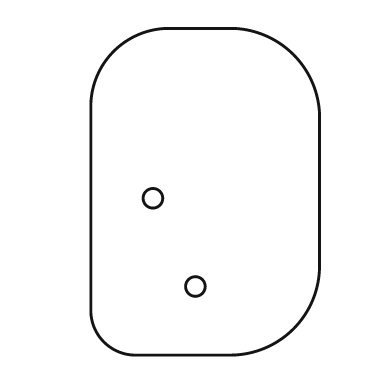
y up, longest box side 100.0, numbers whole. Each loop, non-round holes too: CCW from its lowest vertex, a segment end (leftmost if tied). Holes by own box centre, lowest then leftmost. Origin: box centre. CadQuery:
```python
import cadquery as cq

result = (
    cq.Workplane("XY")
    .moveTo(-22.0, -50.0)
    .lineTo(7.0, -50.0)
    .threePointArc((27.0, -42.0), (35.0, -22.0))
    .lineTo(35.0, 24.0)
    .threePointArc((27.0, 42.0), (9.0, 50.0))
    .lineTo(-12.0, 50.0)
    .threePointArc((-28.0, 43.0), (-35.0, 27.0))
    .lineTo(-35.0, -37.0)
    .threePointArc((-31.0, -46.0), (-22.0, -50.0))
    .close()
    .moveTo(-3.0, -29.0)
    .circle(3.0)
    .moveTo(-16.0, -2.0)
    .circle(3.0)
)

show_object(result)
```